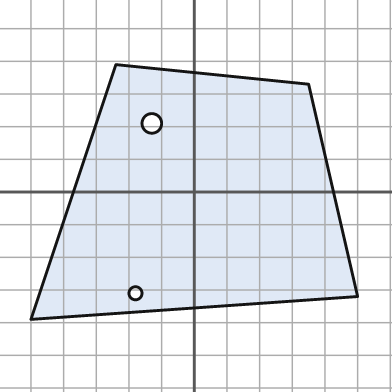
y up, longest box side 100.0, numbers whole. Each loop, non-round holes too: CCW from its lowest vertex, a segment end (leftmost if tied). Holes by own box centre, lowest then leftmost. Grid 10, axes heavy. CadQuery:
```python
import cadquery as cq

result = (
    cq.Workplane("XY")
    .moveTo(-50.0, -39.0)
    .lineTo(50.0, -32.0)
    .lineTo(35.0, 33.0)
    .lineTo(-24.0, 39.0)
    .close()
    .moveTo(-18.0, -31.0)
    .circle(2.0)
    .moveTo(-13.0, 21.0)
    .circle(3.0)
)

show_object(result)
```